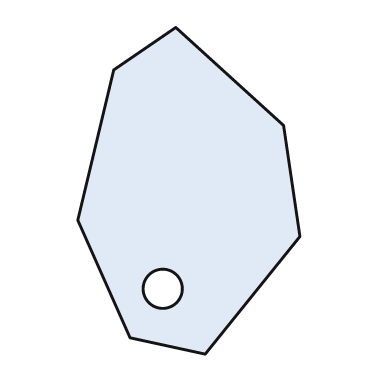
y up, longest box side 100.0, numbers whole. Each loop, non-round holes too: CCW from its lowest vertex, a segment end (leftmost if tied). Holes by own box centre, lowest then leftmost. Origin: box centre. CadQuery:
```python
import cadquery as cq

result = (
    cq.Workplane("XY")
    .moveTo(5.0, -50.0)
    .lineTo(34.0, -14.0)
    .lineTo(29.0, 20.0)
    .lineTo(-4.0, 50.0)
    .lineTo(-23.0, 37.0)
    .lineTo(-34.0, -9.0)
    .lineTo(-18.0, -45.0)
    .close()
    .moveTo(-8.0, -30.0)
    .circle(6.0)
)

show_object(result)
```